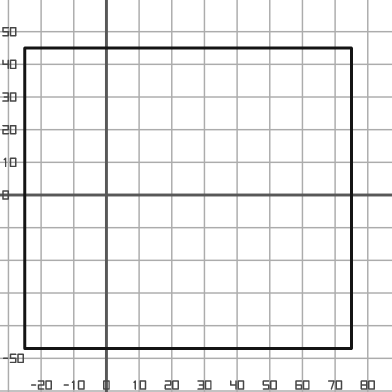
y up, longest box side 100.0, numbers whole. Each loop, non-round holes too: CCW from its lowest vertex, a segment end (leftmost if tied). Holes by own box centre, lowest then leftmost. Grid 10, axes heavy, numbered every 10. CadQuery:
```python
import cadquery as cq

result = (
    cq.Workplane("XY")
    .moveTo(-25.0, -47.0)
    .lineTo(75.0, -47.0)
    .lineTo(75.0, 45.0)
    .lineTo(-25.0, 45.0)
    .close()
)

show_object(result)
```